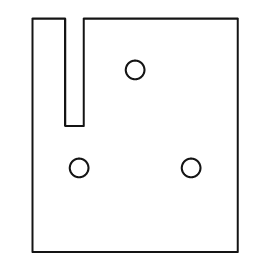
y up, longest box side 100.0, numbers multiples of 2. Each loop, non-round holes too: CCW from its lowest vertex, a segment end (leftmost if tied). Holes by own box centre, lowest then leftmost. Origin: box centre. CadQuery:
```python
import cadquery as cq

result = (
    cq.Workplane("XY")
    .moveTo(-44.0, -50.0)
    .lineTo(44.0, -50.0)
    .lineTo(44.0, 50.0)
    .lineTo(-22.0, 50.0)
    .lineTo(-22.0, 4.0)
    .lineTo(-30.0, 4.0)
    .lineTo(-30.0, 50.0)
    .lineTo(-44.0, 50.0)
    .close()
    .moveTo(-24.0, -14.0)
    .circle(4.0)
    .moveTo(24.0, -14.0)
    .circle(4.0)
    .moveTo(0.0, 28.0)
    .circle(4.0)
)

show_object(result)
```